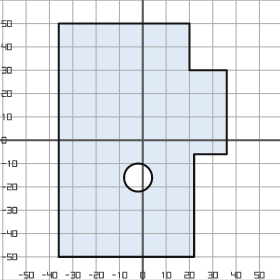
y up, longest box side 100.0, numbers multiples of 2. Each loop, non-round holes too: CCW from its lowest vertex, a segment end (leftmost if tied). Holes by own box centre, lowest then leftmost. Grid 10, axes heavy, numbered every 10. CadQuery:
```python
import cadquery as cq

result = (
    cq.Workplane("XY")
    .moveTo(-36.0, -50.0)
    .lineTo(22.0, -50.0)
    .lineTo(22.0, -6.0)
    .lineTo(36.0, -6.0)
    .lineTo(36.0, 30.0)
    .lineTo(20.0, 30.0)
    .lineTo(20.0, 50.0)
    .lineTo(-36.0, 50.0)
    .close()
    .moveTo(-2.0, -16.0)
    .circle(6.0)
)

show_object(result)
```